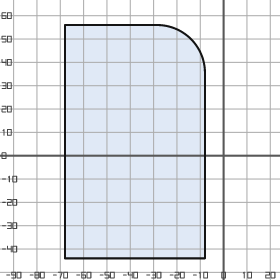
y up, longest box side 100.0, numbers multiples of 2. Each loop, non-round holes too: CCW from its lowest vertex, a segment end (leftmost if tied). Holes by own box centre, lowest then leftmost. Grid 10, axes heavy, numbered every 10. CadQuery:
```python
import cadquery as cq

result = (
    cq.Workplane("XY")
    .moveTo(-68.0, -44.0)
    .lineTo(-8.0, -44.0)
    .lineTo(-8.0, 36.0)
    .threePointArc((-14.0, 50.0), (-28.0, 56.0))
    .lineTo(-68.0, 56.0)
    .close()
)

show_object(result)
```